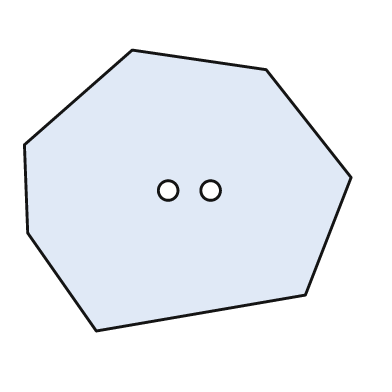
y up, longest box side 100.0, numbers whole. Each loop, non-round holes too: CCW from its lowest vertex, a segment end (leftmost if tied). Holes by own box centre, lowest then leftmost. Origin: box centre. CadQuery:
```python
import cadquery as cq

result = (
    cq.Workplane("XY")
    .moveTo(-28.0, -43.0)
    .lineTo(36.0, -32.0)
    .lineTo(50.0, 4.0)
    .lineTo(24.0, 37.0)
    .lineTo(-17.0, 43.0)
    .lineTo(-50.0, 14.0)
    .lineTo(-49.0, -13.0)
    .close()
    .moveTo(-6.0, 0.0)
    .circle(3.0)
    .moveTo(7.0, 0.0)
    .circle(3.0)
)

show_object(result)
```